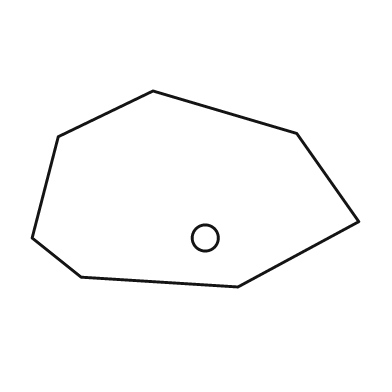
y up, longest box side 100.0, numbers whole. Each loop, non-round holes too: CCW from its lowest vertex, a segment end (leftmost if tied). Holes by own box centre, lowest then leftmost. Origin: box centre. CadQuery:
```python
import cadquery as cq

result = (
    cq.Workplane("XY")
    .moveTo(13.0, -30.0)
    .lineTo(50.0, -10.0)
    .lineTo(31.0, 17.0)
    .lineTo(-13.0, 30.0)
    .lineTo(-42.0, 16.0)
    .lineTo(-50.0, -15.0)
    .lineTo(-35.0, -27.0)
    .close()
    .moveTo(3.0, -15.0)
    .circle(4.0)
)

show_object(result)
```